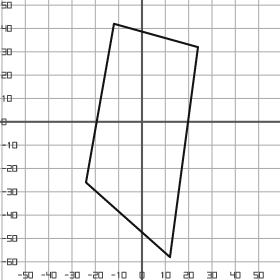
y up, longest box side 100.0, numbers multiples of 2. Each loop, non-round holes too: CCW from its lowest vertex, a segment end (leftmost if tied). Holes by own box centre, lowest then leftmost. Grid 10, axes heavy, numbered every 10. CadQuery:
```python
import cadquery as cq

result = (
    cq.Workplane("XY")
    .moveTo(12.0, -58.0)
    .lineTo(24.0, 32.0)
    .lineTo(-12.0, 42.0)
    .lineTo(-24.0, -26.0)
    .close()
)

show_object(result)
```